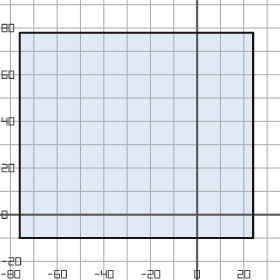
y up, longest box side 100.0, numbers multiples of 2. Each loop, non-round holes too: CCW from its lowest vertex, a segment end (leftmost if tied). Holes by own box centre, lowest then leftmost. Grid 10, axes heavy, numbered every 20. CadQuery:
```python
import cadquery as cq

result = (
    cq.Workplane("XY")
    .moveTo(-76.0, -10.0)
    .lineTo(24.0, -10.0)
    .lineTo(24.0, 78.0)
    .lineTo(-76.0, 78.0)
    .close()
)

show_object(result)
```